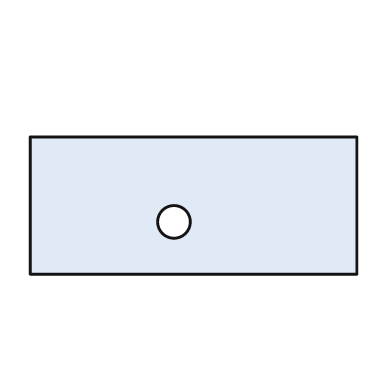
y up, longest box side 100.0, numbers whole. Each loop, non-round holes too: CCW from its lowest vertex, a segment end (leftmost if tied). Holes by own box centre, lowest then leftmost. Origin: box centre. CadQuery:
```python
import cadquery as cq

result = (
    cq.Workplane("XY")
    .moveTo(-50.0, -21.0)
    .lineTo(50.0, -21.0)
    .lineTo(50.0, 21.0)
    .lineTo(-50.0, 21.0)
    .close()
    .moveTo(-6.0, -5.0)
    .circle(5.0)
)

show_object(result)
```